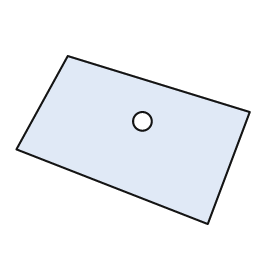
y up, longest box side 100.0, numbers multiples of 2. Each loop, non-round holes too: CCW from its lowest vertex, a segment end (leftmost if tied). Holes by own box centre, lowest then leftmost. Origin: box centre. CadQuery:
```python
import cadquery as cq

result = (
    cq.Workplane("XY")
    .moveTo(32.0, -36.0)
    .lineTo(50.0, 12.0)
    .lineTo(-28.0, 36.0)
    .lineTo(-50.0, -4.0)
    .close()
    .moveTo(4.0, 8.0)
    .circle(4.0)
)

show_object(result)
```